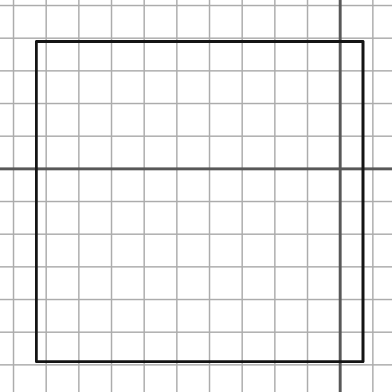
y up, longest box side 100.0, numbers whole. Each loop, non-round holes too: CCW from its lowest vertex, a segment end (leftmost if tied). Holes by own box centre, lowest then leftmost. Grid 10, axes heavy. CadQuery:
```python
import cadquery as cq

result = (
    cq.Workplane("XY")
    .moveTo(-93.0, -59.0)
    .lineTo(7.0, -59.0)
    .lineTo(7.0, 39.0)
    .lineTo(-93.0, 39.0)
    .close()
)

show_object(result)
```